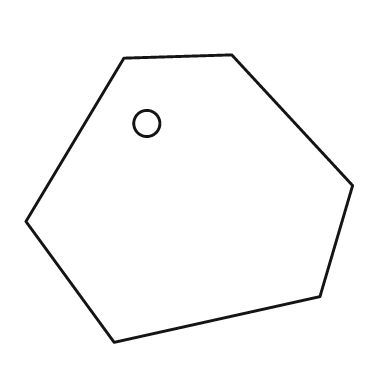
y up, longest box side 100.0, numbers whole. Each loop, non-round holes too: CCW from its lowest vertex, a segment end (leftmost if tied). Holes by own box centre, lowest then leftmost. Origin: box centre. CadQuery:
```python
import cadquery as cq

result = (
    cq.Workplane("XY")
    .moveTo(-23.0, -44.0)
    .lineTo(40.0, -30.0)
    .lineTo(50.0, 4.0)
    .lineTo(13.0, 44.0)
    .lineTo(-20.0, 43.0)
    .lineTo(-50.0, -7.0)
    .close()
    .moveTo(-13.0, 23.0)
    .circle(4.0)
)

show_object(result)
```